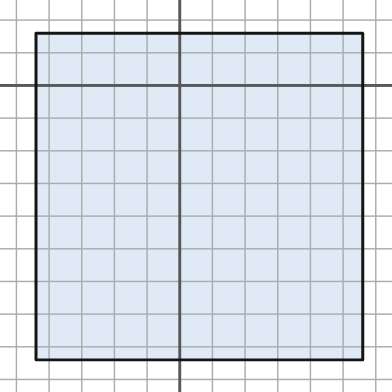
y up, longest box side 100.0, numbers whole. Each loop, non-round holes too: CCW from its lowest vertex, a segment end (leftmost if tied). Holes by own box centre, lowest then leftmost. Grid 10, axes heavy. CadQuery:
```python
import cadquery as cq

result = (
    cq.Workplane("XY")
    .moveTo(-44.0, -84.0)
    .lineTo(56.0, -84.0)
    .lineTo(56.0, 16.0)
    .lineTo(-44.0, 16.0)
    .close()
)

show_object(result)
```